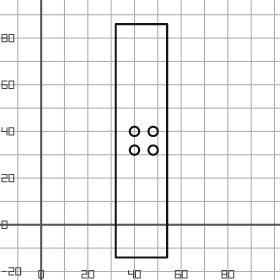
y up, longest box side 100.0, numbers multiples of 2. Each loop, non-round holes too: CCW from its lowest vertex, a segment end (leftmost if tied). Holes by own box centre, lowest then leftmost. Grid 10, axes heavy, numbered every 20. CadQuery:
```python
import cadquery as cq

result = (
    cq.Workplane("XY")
    .moveTo(32.0, -14.0)
    .lineTo(54.0, -14.0)
    .lineTo(54.0, 86.0)
    .lineTo(32.0, 86.0)
    .close()
    .moveTo(40.0, 32.0)
    .circle(2.0)
    .moveTo(48.0, 32.0)
    .circle(2.0)
    .moveTo(40.0, 40.0)
    .circle(2.0)
    .moveTo(48.0, 40.0)
    .circle(2.0)
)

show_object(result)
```